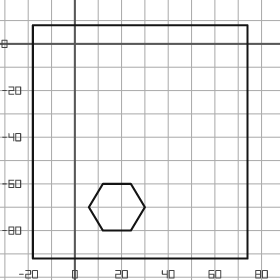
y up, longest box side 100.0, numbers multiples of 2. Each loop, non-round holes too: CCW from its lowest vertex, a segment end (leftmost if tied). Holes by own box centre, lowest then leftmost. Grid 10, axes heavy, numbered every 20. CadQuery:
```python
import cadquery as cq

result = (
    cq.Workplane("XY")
    .moveTo(-18.0, -92.0)
    .lineTo(74.0, -92.0)
    .lineTo(74.0, 8.0)
    .lineTo(-18.0, 8.0)
    .close()
    .moveTo(12.0, -80.0)
    .lineTo(24.0, -80.0)
    .lineTo(30.0, -70.0)
    .lineTo(24.0, -60.0)
    .lineTo(12.0, -60.0)
    .lineTo(6.0, -70.0)
    .close()
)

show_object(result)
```